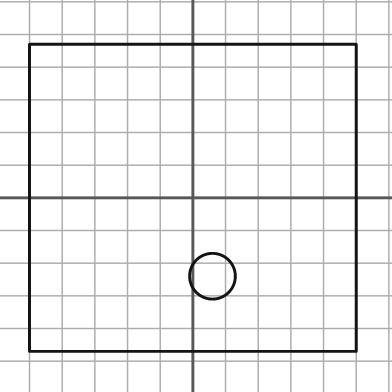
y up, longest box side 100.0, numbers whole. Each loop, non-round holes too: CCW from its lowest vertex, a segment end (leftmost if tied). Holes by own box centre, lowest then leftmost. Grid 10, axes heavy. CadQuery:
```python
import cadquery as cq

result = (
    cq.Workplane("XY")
    .moveTo(-50.0, -47.0)
    .lineTo(50.0, -47.0)
    .lineTo(50.0, 47.0)
    .lineTo(-50.0, 47.0)
    .close()
    .moveTo(6.0, -24.0)
    .circle(7.0)
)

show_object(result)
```